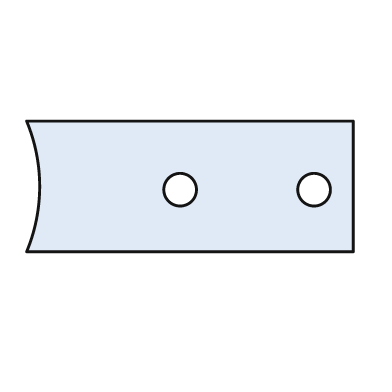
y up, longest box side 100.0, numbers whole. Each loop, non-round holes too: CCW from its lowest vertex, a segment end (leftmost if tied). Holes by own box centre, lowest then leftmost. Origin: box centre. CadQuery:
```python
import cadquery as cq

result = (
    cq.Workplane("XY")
    .moveTo(-50.0, -20.0)
    .lineTo(50.0, -20.0)
    .lineTo(50.0, 20.0)
    .lineTo(-50.0, 20.0)
    .threePointArc((-46.0, 0.0), (-50.0, -20.0))
    .close()
    .moveTo(-3.0, -1.0)
    .circle(5.0)
    .moveTo(38.0, -1.0)
    .circle(5.0)
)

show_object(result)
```